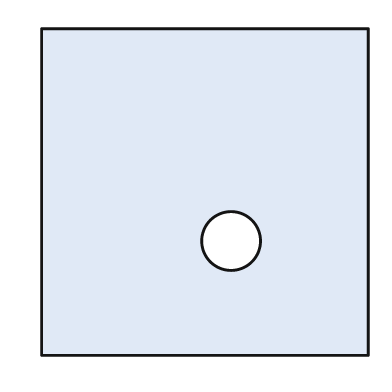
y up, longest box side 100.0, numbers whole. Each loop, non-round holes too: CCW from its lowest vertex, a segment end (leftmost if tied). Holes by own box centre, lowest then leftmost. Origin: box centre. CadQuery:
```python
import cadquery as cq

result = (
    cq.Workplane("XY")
    .moveTo(-50.0, -50.0)
    .lineTo(50.0, -50.0)
    .lineTo(50.0, 50.0)
    .lineTo(-50.0, 50.0)
    .close()
    .moveTo(8.0, -15.0)
    .circle(9.0)
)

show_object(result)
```